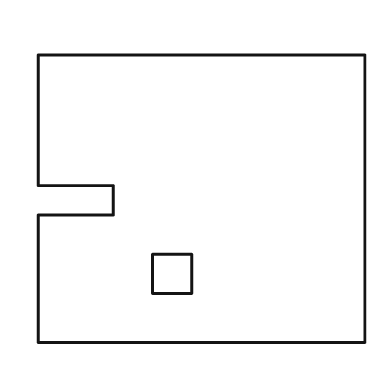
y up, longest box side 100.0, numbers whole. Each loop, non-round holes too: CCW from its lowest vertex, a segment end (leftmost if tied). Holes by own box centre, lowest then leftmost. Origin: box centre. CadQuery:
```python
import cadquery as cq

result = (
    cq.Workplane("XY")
    .moveTo(-50.0, -44.0)
    .lineTo(50.0, -44.0)
    .lineTo(50.0, 44.0)
    .lineTo(-50.0, 44.0)
    .lineTo(-50.0, 4.0)
    .lineTo(-27.0, 4.0)
    .lineTo(-27.0, -5.0)
    .lineTo(-50.0, -5.0)
    .close()
    .moveTo(-15.0, -29.0)
    .lineTo(-3.0, -29.0)
    .lineTo(-3.0, -17.0)
    .lineTo(-15.0, -17.0)
    .close()
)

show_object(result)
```